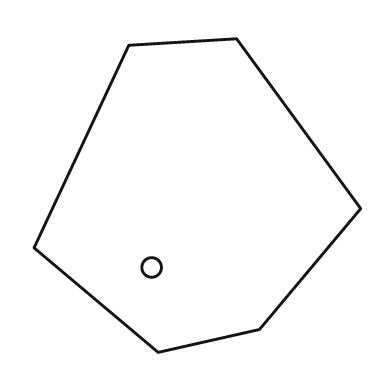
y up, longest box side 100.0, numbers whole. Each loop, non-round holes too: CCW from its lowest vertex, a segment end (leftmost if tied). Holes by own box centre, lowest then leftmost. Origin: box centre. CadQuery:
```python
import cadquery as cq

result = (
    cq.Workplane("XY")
    .moveTo(-12.0, -48.0)
    .lineTo(19.0, -41.0)
    .lineTo(50.0, -4.0)
    .lineTo(12.0, 48.0)
    .lineTo(-21.0, 46.0)
    .lineTo(-50.0, -16.0)
    .close()
    .moveTo(-14.0, -22.0)
    .circle(3.0)
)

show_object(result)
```